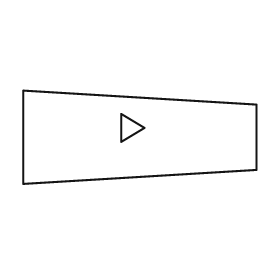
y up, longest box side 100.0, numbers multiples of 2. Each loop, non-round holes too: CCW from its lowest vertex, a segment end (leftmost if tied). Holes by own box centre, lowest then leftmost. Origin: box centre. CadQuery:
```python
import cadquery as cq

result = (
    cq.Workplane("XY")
    .moveTo(-50.0, -20.0)
    .lineTo(50.0, -14.0)
    .lineTo(50.0, 14.0)
    .lineTo(-50.0, 20.0)
    .close()
    .moveTo(-8.0, -2.0)
    .lineTo(2.0, 4.0)
    .lineTo(-8.0, 10.0)
    .close()
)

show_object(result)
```